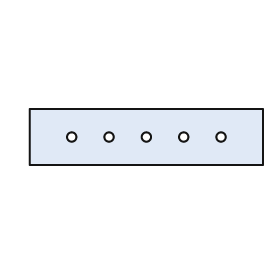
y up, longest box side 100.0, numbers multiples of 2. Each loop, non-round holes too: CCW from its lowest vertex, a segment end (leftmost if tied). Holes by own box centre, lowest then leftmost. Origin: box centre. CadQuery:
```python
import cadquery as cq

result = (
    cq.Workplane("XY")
    .moveTo(-50.0, -12.0)
    .lineTo(50.0, -12.0)
    .lineTo(50.0, 12.0)
    .lineTo(-50.0, 12.0)
    .close()
    .moveTo(-32.0, 0.0)
    .circle(2.0)
    .moveTo(-16.0, 0.0)
    .circle(2.0)
    .moveTo(0.0, 0.0)
    .circle(2.0)
    .moveTo(16.0, 0.0)
    .circle(2.0)
    .moveTo(32.0, 0.0)
    .circle(2.0)
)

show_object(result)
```